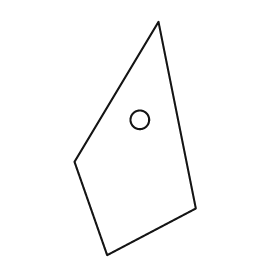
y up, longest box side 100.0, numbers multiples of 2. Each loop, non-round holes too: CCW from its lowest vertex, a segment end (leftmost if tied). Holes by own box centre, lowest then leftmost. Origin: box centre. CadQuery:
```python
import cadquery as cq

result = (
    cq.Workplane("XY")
    .moveTo(-12.0, -50.0)
    .lineTo(26.0, -30.0)
    .lineTo(10.0, 50.0)
    .lineTo(-26.0, -10.0)
    .close()
    .moveTo(2.0, 8.0)
    .circle(4.0)
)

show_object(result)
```